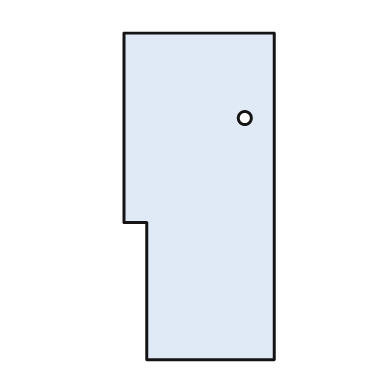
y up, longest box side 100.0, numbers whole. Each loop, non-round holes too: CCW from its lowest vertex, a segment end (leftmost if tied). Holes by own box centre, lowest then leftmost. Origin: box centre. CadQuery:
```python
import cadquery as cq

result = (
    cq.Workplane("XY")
    .moveTo(-16.0, -50.0)
    .lineTo(23.0, -50.0)
    .lineTo(23.0, 50.0)
    .lineTo(-23.0, 50.0)
    .lineTo(-23.0, -8.0)
    .lineTo(-16.0, -8.0)
    .close()
    .moveTo(14.0, 24.0)
    .circle(2.0)
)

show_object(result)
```